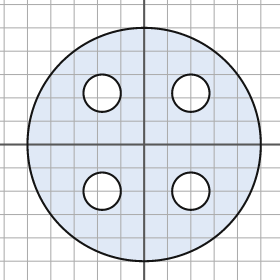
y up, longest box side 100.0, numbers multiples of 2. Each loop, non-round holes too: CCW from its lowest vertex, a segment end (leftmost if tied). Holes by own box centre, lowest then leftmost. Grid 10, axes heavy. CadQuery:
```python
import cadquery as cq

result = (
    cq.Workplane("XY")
    .moveTo(0.0, 0.0)
    .circle(50.0)
    .moveTo(-18.0, -20.0)
    .circle(8.0)
    .moveTo(20.0, -20.0)
    .circle(8.0)
    .moveTo(-18.0, 22.0)
    .circle(8.0)
    .moveTo(20.0, 22.0)
    .circle(8.0)
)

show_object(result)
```